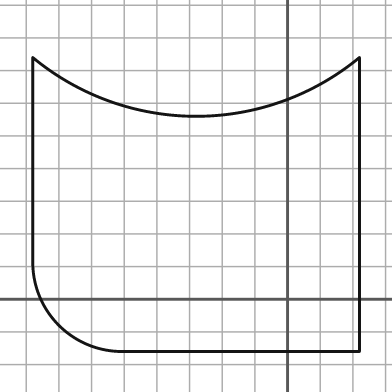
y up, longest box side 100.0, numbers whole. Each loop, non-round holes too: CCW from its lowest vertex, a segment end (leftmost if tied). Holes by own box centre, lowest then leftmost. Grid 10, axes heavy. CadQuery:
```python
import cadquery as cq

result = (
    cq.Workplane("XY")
    .moveTo(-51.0, -16.0)
    .lineTo(22.0, -16.0)
    .lineTo(22.0, 74.0)
    .threePointArc((-28.0, 56.0), (-78.0, 74.0))
    .lineTo(-78.0, 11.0)
    .threePointArc((-70.0, -8.0), (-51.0, -16.0))
    .close()
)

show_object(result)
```